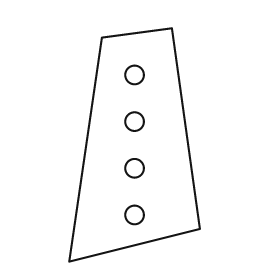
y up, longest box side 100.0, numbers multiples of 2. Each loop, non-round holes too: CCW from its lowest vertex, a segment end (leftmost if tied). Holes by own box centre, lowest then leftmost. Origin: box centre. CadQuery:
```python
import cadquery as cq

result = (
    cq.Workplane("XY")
    .moveTo(-28.0, -50.0)
    .lineTo(28.0, -36.0)
    .lineTo(16.0, 50.0)
    .lineTo(-14.0, 46.0)
    .close()
    .moveTo(0.0, -30.0)
    .circle(4.0)
    .moveTo(0.0, -10.0)
    .circle(4.0)
    .moveTo(0.0, 10.0)
    .circle(4.0)
    .moveTo(0.0, 30.0)
    .circle(4.0)
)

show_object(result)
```